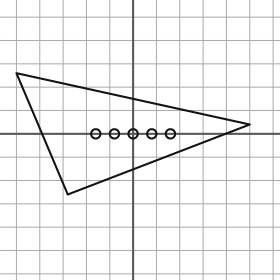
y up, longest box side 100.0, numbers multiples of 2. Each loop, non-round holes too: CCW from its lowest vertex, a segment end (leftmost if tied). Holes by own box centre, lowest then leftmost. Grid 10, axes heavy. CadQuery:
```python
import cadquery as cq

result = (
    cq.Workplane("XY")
    .moveTo(-28.0, -26.0)
    .lineTo(50.0, 4.0)
    .lineTo(-50.0, 26.0)
    .close()
    .moveTo(-16.0, 0.0)
    .circle(2.0)
    .moveTo(-8.0, 0.0)
    .circle(2.0)
    .moveTo(0.0, 0.0)
    .circle(2.0)
    .moveTo(8.0, 0.0)
    .circle(2.0)
    .moveTo(16.0, 0.0)
    .circle(2.0)
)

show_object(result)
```